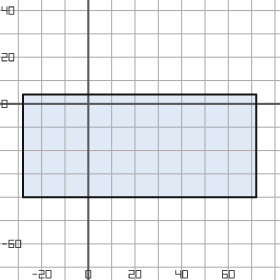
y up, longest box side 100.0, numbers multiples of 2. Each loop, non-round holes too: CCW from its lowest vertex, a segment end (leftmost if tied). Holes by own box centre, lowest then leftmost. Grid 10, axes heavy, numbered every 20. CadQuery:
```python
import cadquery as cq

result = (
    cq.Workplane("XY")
    .moveTo(-28.0, -40.0)
    .lineTo(72.0, -40.0)
    .lineTo(72.0, 4.0)
    .lineTo(-28.0, 4.0)
    .close()
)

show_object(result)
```